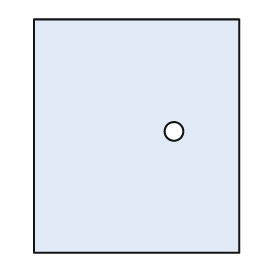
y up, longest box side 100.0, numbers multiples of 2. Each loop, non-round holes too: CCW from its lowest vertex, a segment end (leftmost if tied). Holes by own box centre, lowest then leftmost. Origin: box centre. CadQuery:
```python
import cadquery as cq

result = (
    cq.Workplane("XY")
    .moveTo(-44.0, -50.0)
    .lineTo(44.0, -50.0)
    .lineTo(44.0, 50.0)
    .lineTo(-44.0, 50.0)
    .close()
    .moveTo(16.0, 2.0)
    .circle(4.0)
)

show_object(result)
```